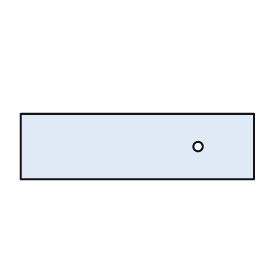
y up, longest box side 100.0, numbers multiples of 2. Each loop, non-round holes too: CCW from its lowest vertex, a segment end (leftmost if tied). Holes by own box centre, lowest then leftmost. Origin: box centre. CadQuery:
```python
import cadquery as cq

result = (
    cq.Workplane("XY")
    .moveTo(-50.0, -14.0)
    .lineTo(50.0, -14.0)
    .lineTo(50.0, 14.0)
    .lineTo(-50.0, 14.0)
    .close()
    .moveTo(26.0, 0.0)
    .circle(2.0)
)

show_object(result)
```